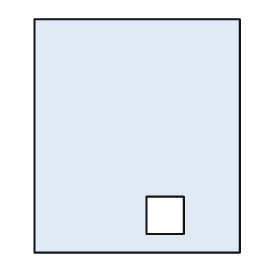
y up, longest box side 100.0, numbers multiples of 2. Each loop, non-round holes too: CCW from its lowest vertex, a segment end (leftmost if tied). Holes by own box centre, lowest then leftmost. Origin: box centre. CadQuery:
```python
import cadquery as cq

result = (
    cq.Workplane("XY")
    .moveTo(-44.0, -50.0)
    .lineTo(44.0, -50.0)
    .lineTo(44.0, 50.0)
    .lineTo(-44.0, 50.0)
    .close()
    .moveTo(4.0, -42.0)
    .lineTo(20.0, -42.0)
    .lineTo(20.0, -26.0)
    .lineTo(4.0, -26.0)
    .close()
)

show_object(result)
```